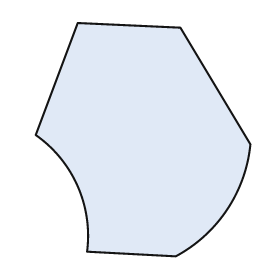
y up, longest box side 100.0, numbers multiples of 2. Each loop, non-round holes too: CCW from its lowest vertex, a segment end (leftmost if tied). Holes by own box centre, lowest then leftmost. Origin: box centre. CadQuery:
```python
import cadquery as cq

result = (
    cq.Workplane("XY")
    .moveTo(14.0, -50.0)
    .threePointArc((36.0, -30.0), (46.0, -2.0))
    .lineTo(16.0, 48.0)
    .lineTo(-28.0, 50.0)
    .lineTo(-46.0, 2.0)
    .threePointArc((-28.0, -20.0), (-24.0, -48.0))
    .close()
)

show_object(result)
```